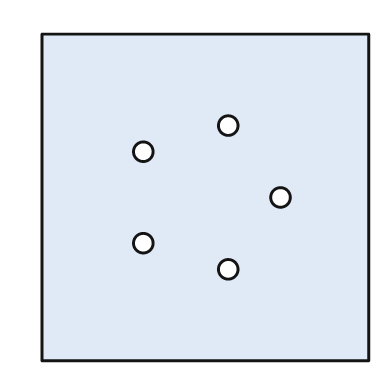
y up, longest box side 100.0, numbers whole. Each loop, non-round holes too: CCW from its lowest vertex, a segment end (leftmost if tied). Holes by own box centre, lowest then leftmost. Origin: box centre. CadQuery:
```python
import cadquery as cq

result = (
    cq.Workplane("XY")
    .moveTo(-50.0, -50.0)
    .lineTo(50.0, -50.0)
    .lineTo(50.0, 50.0)
    .lineTo(-50.0, 50.0)
    .close()
    .moveTo(7.0, -22.0)
    .circle(3.0)
    .moveTo(-19.0, -14.0)
    .circle(3.0)
    .moveTo(23.0, 0.0)
    .circle(3.0)
    .moveTo(-19.0, 14.0)
    .circle(3.0)
    .moveTo(7.0, 22.0)
    .circle(3.0)
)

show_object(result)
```